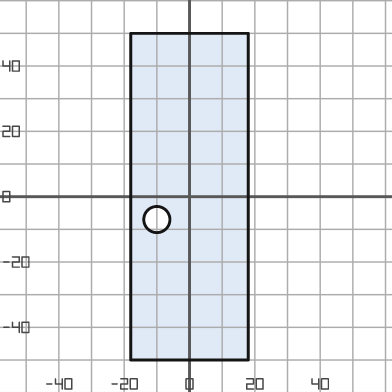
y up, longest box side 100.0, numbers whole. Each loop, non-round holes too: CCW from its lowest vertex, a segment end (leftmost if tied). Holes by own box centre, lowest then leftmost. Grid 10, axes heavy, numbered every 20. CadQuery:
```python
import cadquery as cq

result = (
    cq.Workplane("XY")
    .moveTo(-18.0, -50.0)
    .lineTo(18.0, -50.0)
    .lineTo(18.0, 50.0)
    .lineTo(-18.0, 50.0)
    .close()
    .moveTo(-10.0, -7.0)
    .circle(4.0)
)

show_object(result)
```